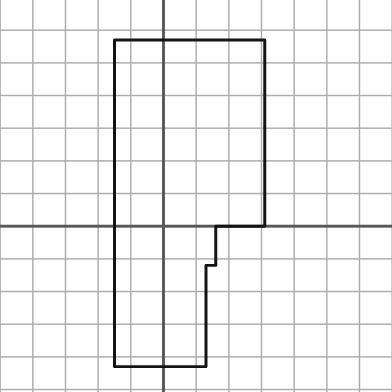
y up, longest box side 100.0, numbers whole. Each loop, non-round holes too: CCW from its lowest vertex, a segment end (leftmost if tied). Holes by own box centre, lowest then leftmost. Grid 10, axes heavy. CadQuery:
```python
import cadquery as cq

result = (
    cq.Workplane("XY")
    .moveTo(-15.0, -43.0)
    .lineTo(13.0, -43.0)
    .lineTo(13.0, -12.0)
    .lineTo(16.0, -12.0)
    .lineTo(16.0, 0.0)
    .lineTo(31.0, 0.0)
    .lineTo(31.0, 57.0)
    .lineTo(-15.0, 57.0)
    .close()
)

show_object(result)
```